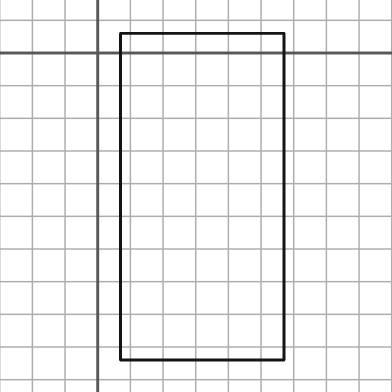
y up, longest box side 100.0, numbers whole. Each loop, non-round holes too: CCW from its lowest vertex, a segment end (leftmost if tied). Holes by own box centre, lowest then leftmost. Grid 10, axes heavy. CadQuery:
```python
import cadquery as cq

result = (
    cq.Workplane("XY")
    .moveTo(7.0, -94.0)
    .lineTo(57.0, -94.0)
    .lineTo(57.0, 6.0)
    .lineTo(7.0, 6.0)
    .close()
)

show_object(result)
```